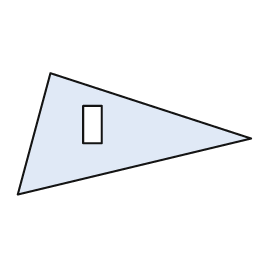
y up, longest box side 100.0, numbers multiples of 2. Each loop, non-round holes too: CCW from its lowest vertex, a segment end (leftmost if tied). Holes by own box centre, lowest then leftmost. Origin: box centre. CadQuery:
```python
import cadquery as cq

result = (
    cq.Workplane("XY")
    .moveTo(-50.0, -26.0)
    .lineTo(50.0, -2.0)
    .lineTo(-36.0, 26.0)
    .close()
    .moveTo(-22.0, -4.0)
    .lineTo(-14.0, -4.0)
    .lineTo(-14.0, 12.0)
    .lineTo(-22.0, 12.0)
    .close()
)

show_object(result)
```